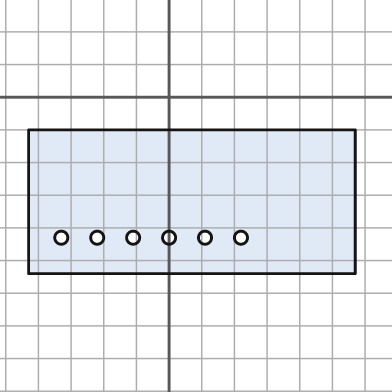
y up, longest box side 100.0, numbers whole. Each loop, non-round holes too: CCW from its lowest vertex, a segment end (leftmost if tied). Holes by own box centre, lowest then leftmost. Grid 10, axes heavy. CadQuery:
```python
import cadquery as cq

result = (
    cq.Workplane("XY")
    .moveTo(-43.0, -54.0)
    .lineTo(57.0, -54.0)
    .lineTo(57.0, -10.0)
    .lineTo(-43.0, -10.0)
    .close()
    .moveTo(-33.0, -43.0)
    .circle(2.0)
    .moveTo(-22.0, -43.0)
    .circle(2.0)
    .moveTo(-11.0, -43.0)
    .circle(2.0)
    .moveTo(0.0, -43.0)
    .circle(2.0)
    .moveTo(11.0, -43.0)
    .circle(2.0)
    .moveTo(22.0, -43.0)
    .circle(2.0)
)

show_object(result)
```